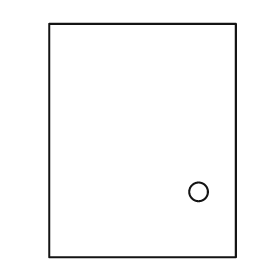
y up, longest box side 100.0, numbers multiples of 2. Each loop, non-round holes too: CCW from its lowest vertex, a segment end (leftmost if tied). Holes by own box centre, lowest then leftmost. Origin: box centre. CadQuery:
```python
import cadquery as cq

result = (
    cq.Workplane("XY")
    .moveTo(-40.0, -50.0)
    .lineTo(40.0, -50.0)
    .lineTo(40.0, 50.0)
    .lineTo(-40.0, 50.0)
    .close()
    .moveTo(24.0, -22.0)
    .circle(4.0)
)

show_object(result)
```